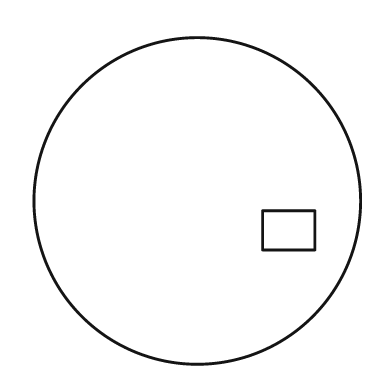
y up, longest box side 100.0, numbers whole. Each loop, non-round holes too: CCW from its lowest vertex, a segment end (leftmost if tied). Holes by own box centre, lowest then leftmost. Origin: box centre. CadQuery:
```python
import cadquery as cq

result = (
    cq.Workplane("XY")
    .moveTo(0.0, 0.0)
    .circle(50.0)
    .moveTo(20.0, -15.0)
    .lineTo(36.0, -15.0)
    .lineTo(36.0, -3.0)
    .lineTo(20.0, -3.0)
    .close()
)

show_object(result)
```